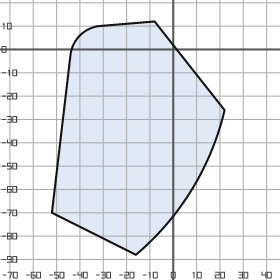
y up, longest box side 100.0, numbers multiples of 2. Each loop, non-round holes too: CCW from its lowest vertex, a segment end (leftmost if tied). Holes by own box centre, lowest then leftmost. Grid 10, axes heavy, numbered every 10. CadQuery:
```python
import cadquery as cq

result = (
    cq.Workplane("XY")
    .moveTo(-16.0, -88.0)
    .threePointArc((8.0, -60.0), (22.0, -26.0))
    .lineTo(-8.0, 12.0)
    .lineTo(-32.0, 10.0)
    .threePointArc((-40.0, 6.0), (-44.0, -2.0))
    .lineTo(-52.0, -70.0)
    .close()
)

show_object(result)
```